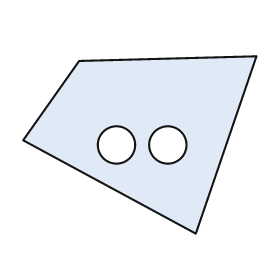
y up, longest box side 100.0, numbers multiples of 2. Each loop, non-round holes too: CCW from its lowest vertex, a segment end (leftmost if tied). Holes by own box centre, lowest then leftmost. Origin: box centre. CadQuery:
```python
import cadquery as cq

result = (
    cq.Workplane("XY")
    .moveTo(24.0, -38.0)
    .lineTo(50.0, 38.0)
    .lineTo(-26.0, 36.0)
    .lineTo(-50.0, 2.0)
    .close()
    .moveTo(-10.0, 0.0)
    .circle(8.0)
    .moveTo(12.0, 0.0)
    .circle(8.0)
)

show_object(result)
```